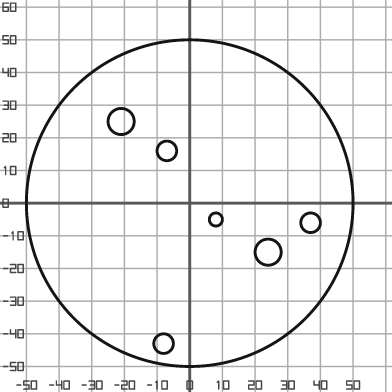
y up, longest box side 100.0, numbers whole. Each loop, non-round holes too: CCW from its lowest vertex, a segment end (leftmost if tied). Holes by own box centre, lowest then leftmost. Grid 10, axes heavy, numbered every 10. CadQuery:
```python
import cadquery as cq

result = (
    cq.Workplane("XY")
    .moveTo(0.0, 0.0)
    .circle(50.0)
    .moveTo(-8.0, -43.0)
    .circle(3.0)
    .moveTo(24.0, -15.0)
    .circle(4.0)
    .moveTo(37.0, -6.0)
    .circle(3.0)
    .moveTo(8.0, -5.0)
    .circle(2.0)
    .moveTo(-7.0, 16.0)
    .circle(3.0)
    .moveTo(-21.0, 25.0)
    .circle(4.0)
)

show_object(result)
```